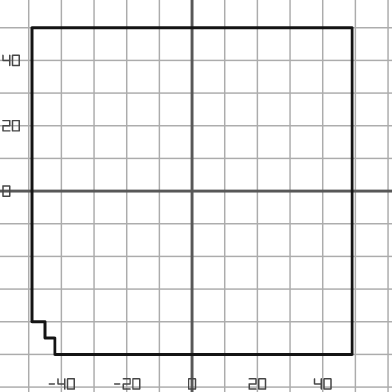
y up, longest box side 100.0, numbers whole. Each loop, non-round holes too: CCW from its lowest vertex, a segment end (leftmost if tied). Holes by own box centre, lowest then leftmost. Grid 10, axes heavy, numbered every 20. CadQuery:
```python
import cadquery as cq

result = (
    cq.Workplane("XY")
    .moveTo(-42.0, -50.0)
    .lineTo(49.0, -50.0)
    .lineTo(49.0, 50.0)
    .lineTo(-49.0, 50.0)
    .lineTo(-49.0, -40.0)
    .lineTo(-45.0, -40.0)
    .lineTo(-45.0, -45.0)
    .lineTo(-42.0, -45.0)
    .close()
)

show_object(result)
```